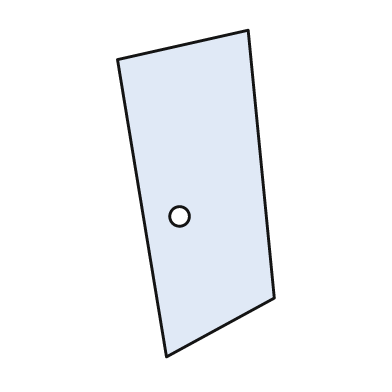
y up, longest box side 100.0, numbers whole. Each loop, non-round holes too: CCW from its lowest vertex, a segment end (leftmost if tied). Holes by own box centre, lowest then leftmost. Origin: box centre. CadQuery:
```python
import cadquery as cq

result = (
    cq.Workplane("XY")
    .moveTo(-9.0, -50.0)
    .lineTo(24.0, -32.0)
    .lineTo(16.0, 50.0)
    .lineTo(-24.0, 41.0)
    .close()
    .moveTo(-5.0, -7.0)
    .circle(3.0)
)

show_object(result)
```